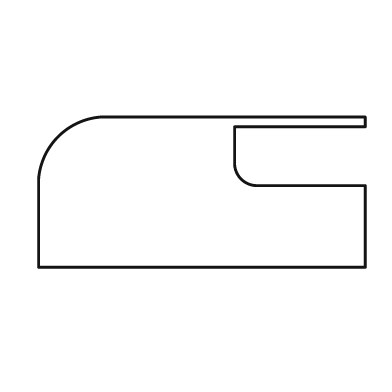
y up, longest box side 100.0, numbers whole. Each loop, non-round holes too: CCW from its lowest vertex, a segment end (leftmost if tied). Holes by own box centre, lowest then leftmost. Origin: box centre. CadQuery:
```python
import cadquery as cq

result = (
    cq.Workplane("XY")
    .moveTo(-50.0, -23.0)
    .lineTo(50.0, -23.0)
    .lineTo(50.0, 2.0)
    .lineTo(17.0, 2.0)
    .threePointArc((12.0, 4.0), (10.0, 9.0))
    .lineTo(10.0, 20.0)
    .lineTo(50.0, 20.0)
    .lineTo(50.0, 23.0)
    .lineTo(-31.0, 23.0)
    .threePointArc((-44.0, 17.0), (-50.0, 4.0))
    .close()
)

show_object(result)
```